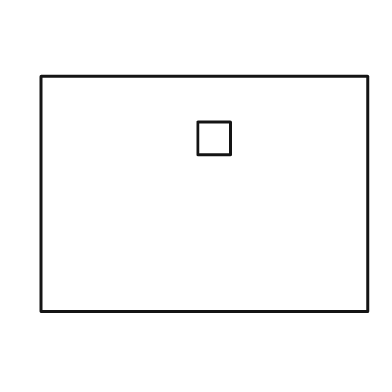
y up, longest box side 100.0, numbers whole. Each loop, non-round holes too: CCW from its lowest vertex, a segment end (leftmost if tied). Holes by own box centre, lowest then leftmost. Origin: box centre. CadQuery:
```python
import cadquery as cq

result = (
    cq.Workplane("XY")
    .moveTo(-50.0, -36.0)
    .lineTo(50.0, -36.0)
    .lineTo(50.0, 36.0)
    .lineTo(-50.0, 36.0)
    .close()
    .moveTo(-2.0, 12.0)
    .lineTo(8.0, 12.0)
    .lineTo(8.0, 22.0)
    .lineTo(-2.0, 22.0)
    .close()
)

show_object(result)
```